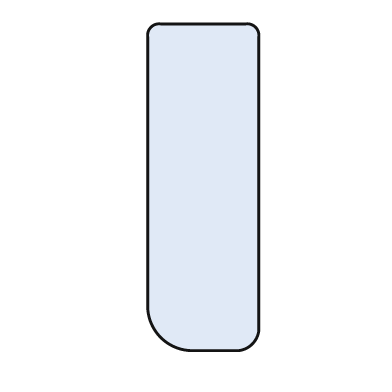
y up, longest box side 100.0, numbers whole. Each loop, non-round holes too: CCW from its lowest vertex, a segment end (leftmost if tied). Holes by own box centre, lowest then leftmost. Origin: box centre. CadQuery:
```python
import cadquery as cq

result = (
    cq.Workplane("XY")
    .moveTo(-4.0, -50.0)
    .lineTo(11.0, -50.0)
    .threePointArc((15.0, -48.0), (17.0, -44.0))
    .lineTo(17.0, 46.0)
    .threePointArc((16.0, 49.0), (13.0, 50.0))
    .lineTo(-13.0, 50.0)
    .threePointArc((-16.0, 49.0), (-17.0, 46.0))
    .lineTo(-17.0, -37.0)
    .threePointArc((-13.0, -46.0), (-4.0, -50.0))
    .close()
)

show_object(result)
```